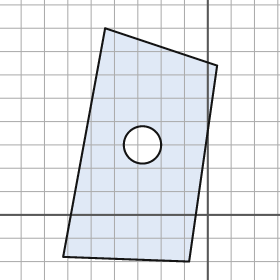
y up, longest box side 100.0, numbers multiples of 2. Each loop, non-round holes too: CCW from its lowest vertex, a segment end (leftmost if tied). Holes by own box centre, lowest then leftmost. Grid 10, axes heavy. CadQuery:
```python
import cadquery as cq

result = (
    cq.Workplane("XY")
    .moveTo(-8.0, -20.0)
    .lineTo(4.0, 64.0)
    .lineTo(-44.0, 80.0)
    .lineTo(-62.0, -18.0)
    .close()
    .moveTo(-28.0, 30.0)
    .circle(8.0)
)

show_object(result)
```